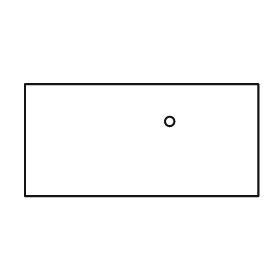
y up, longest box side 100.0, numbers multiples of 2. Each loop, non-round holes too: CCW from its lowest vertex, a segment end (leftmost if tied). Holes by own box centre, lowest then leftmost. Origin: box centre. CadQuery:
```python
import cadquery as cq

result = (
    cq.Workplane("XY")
    .moveTo(-50.0, -24.0)
    .lineTo(50.0, -24.0)
    .lineTo(50.0, 24.0)
    .lineTo(-50.0, 24.0)
    .close()
    .moveTo(12.0, 8.0)
    .circle(2.0)
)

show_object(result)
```